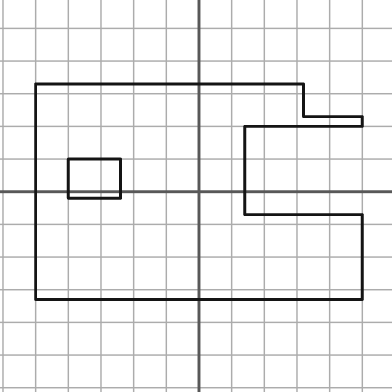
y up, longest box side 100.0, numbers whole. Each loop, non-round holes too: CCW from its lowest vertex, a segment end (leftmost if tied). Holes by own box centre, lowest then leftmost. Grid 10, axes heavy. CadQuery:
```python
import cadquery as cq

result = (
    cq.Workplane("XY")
    .moveTo(-50.0, -33.0)
    .lineTo(50.0, -33.0)
    .lineTo(50.0, -7.0)
    .lineTo(14.0, -7.0)
    .lineTo(14.0, 20.0)
    .lineTo(50.0, 20.0)
    .lineTo(50.0, 23.0)
    .lineTo(32.0, 23.0)
    .lineTo(32.0, 33.0)
    .lineTo(-50.0, 33.0)
    .close()
    .moveTo(-40.0, -2.0)
    .lineTo(-24.0, -2.0)
    .lineTo(-24.0, 10.0)
    .lineTo(-40.0, 10.0)
    .close()
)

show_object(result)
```